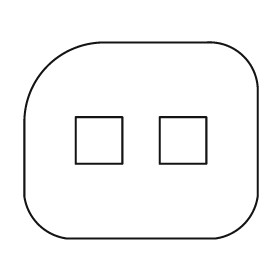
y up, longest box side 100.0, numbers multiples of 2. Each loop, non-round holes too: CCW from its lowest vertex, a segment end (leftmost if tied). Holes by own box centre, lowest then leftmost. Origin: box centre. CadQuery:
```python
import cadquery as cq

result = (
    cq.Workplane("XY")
    .moveTo(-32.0, -42.0)
    .lineTo(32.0, -42.0)
    .threePointArc((44.0, -36.0), (50.0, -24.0))
    .lineTo(50.0, 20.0)
    .threePointArc((44.0, 36.0), (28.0, 42.0))
    .lineTo(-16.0, 42.0)
    .threePointArc((-40.0, 32.0), (-50.0, 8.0))
    .lineTo(-50.0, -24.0)
    .threePointArc((-44.0, -36.0), (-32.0, -42.0))
    .close()
    .moveTo(-28.0, -10.0)
    .lineTo(-8.0, -10.0)
    .lineTo(-8.0, 10.0)
    .lineTo(-28.0, 10.0)
    .close()
    .moveTo(8.0, -10.0)
    .lineTo(28.0, -10.0)
    .lineTo(28.0, 10.0)
    .lineTo(8.0, 10.0)
    .close()
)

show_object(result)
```